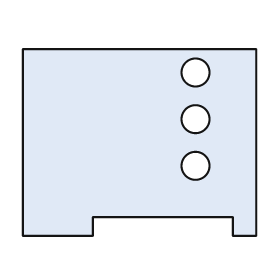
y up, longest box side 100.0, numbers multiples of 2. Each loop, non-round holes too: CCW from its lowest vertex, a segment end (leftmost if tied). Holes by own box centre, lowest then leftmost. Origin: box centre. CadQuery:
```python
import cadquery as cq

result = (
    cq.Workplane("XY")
    .moveTo(-50.0, -40.0)
    .lineTo(-20.0, -40.0)
    .lineTo(-20.0, -32.0)
    .lineTo(40.0, -32.0)
    .lineTo(40.0, -40.0)
    .lineTo(50.0, -40.0)
    .lineTo(50.0, 40.0)
    .lineTo(-50.0, 40.0)
    .close()
    .moveTo(24.0, -10.0)
    .circle(6.0)
    .moveTo(24.0, 10.0)
    .circle(6.0)
    .moveTo(24.0, 30.0)
    .circle(6.0)
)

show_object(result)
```